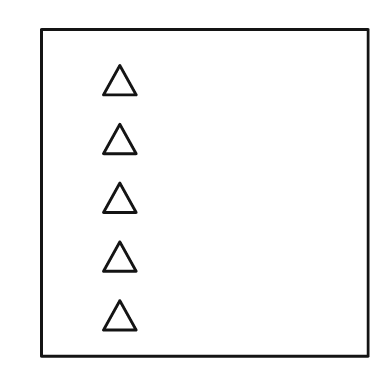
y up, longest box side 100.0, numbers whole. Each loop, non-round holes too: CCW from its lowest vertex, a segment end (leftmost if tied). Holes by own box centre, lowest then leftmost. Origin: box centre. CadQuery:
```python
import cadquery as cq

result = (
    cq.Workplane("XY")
    .moveTo(-50.0, -50.0)
    .lineTo(50.0, -50.0)
    .lineTo(50.0, 50.0)
    .lineTo(-50.0, 50.0)
    .close()
    .moveTo(-31.0, -42.0)
    .lineTo(-21.0, -42.0)
    .lineTo(-26.0, -33.0)
    .close()
    .moveTo(-31.0, -24.0)
    .lineTo(-21.0, -24.0)
    .lineTo(-26.0, -15.0)
    .close()
    .moveTo(-31.0, -6.0)
    .lineTo(-21.0, -6.0)
    .lineTo(-26.0, 3.0)
    .close()
    .moveTo(-31.0, 12.0)
    .lineTo(-21.0, 12.0)
    .lineTo(-26.0, 21.0)
    .close()
    .moveTo(-31.0, 30.0)
    .lineTo(-21.0, 30.0)
    .lineTo(-26.0, 39.0)
    .close()
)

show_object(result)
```